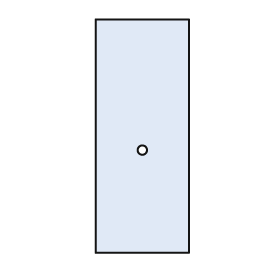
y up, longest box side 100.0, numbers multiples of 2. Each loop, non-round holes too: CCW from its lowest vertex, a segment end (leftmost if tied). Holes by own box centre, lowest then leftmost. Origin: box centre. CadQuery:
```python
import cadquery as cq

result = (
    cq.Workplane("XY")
    .moveTo(-20.0, -50.0)
    .lineTo(20.0, -50.0)
    .lineTo(20.0, 50.0)
    .lineTo(-20.0, 50.0)
    .close()
    .moveTo(0.0, -6.0)
    .circle(2.0)
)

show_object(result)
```